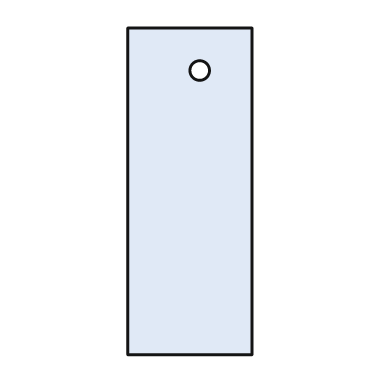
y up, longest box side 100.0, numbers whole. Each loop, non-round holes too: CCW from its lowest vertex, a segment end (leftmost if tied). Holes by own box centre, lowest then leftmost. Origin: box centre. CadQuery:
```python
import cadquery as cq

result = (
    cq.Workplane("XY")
    .moveTo(-19.0, -50.0)
    .lineTo(19.0, -50.0)
    .lineTo(19.0, 50.0)
    .lineTo(-19.0, 50.0)
    .close()
    .moveTo(3.0, 37.0)
    .circle(3.0)
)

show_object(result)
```